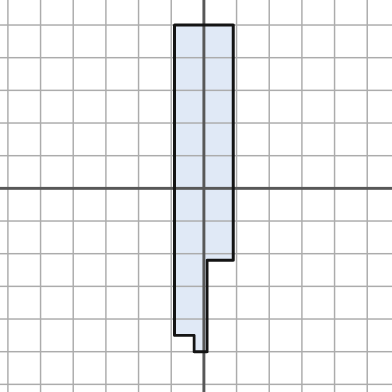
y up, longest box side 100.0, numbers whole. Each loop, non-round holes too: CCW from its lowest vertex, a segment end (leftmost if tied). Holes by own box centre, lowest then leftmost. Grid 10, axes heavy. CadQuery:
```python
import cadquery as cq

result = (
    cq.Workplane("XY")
    .moveTo(-3.0, -50.0)
    .lineTo(1.0, -50.0)
    .lineTo(1.0, -22.0)
    .lineTo(9.0, -22.0)
    .lineTo(9.0, 50.0)
    .lineTo(-9.0, 50.0)
    .lineTo(-9.0, -45.0)
    .lineTo(-3.0, -45.0)
    .close()
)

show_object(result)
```